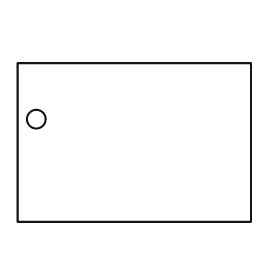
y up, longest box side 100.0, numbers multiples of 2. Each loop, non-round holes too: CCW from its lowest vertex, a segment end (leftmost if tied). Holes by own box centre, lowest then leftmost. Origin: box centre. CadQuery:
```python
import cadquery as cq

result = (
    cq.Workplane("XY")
    .moveTo(-50.0, -34.0)
    .lineTo(50.0, -34.0)
    .lineTo(50.0, 34.0)
    .lineTo(-50.0, 34.0)
    .close()
    .moveTo(-42.0, 10.0)
    .circle(4.0)
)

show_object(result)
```